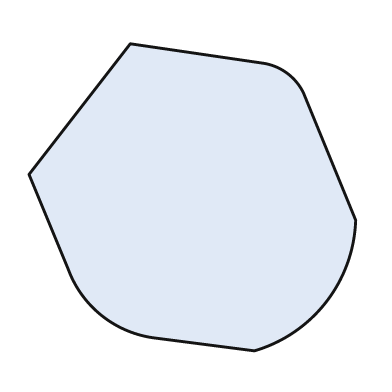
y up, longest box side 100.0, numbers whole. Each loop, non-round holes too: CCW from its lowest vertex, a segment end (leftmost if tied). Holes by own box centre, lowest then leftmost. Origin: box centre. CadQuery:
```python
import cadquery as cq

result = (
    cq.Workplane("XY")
    .moveTo(19.0, -47.0)
    .threePointArc((41.0, -32.0), (50.0, -7.0))
    .lineTo(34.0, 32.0)
    .threePointArc((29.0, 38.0), (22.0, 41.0))
    .lineTo(-19.0, 47.0)
    .lineTo(-50.0, 7.0)
    .lineTo(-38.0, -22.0)
    .threePointArc((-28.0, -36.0), (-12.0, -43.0))
    .close()
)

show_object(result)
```